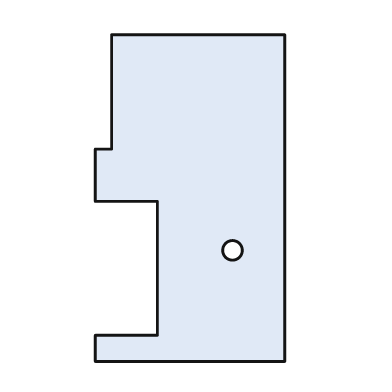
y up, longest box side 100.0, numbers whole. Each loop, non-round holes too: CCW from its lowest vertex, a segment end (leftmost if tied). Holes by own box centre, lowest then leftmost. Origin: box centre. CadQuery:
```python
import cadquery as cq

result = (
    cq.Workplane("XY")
    .moveTo(-29.0, -50.0)
    .lineTo(29.0, -50.0)
    .lineTo(29.0, 50.0)
    .lineTo(-24.0, 50.0)
    .lineTo(-24.0, 15.0)
    .lineTo(-29.0, 15.0)
    .lineTo(-29.0, -1.0)
    .lineTo(-10.0, -1.0)
    .lineTo(-10.0, -42.0)
    .lineTo(-29.0, -42.0)
    .close()
    .moveTo(13.0, -16.0)
    .circle(3.0)
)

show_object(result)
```